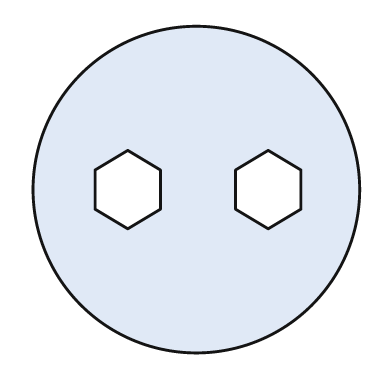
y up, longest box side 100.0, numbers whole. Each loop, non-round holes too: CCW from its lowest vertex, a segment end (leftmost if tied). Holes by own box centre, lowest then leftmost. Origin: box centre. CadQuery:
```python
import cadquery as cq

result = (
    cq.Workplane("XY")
    .moveTo(0.0, 0.0)
    .circle(50.0)
    .moveTo(-21.0, -12.0)
    .lineTo(-11.0, -6.0)
    .lineTo(-11.0, 6.0)
    .lineTo(-21.0, 12.0)
    .lineTo(-31.0, 6.0)
    .lineTo(-31.0, -6.0)
    .close()
    .moveTo(22.0, -12.0)
    .lineTo(32.0, -6.0)
    .lineTo(32.0, 6.0)
    .lineTo(22.0, 12.0)
    .lineTo(12.0, 6.0)
    .lineTo(12.0, -6.0)
    .close()
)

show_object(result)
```